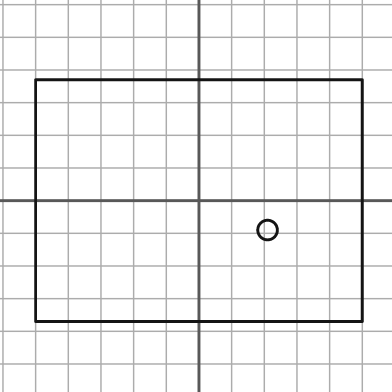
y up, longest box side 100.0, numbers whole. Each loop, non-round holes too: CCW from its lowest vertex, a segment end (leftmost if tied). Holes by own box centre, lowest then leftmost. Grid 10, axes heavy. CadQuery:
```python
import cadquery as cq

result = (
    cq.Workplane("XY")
    .moveTo(-50.0, -37.0)
    .lineTo(50.0, -37.0)
    .lineTo(50.0, 37.0)
    .lineTo(-50.0, 37.0)
    .close()
    .moveTo(21.0, -9.0)
    .circle(3.0)
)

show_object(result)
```